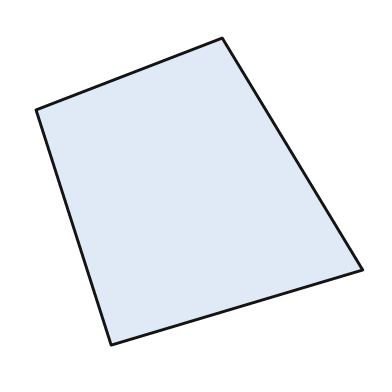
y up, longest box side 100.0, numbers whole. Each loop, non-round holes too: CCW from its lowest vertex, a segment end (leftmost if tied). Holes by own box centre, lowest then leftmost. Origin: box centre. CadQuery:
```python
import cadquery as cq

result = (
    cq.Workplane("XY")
    .moveTo(-27.0, -47.0)
    .lineTo(50.0, -24.0)
    .lineTo(7.0, 47.0)
    .lineTo(-50.0, 25.0)
    .close()
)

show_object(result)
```